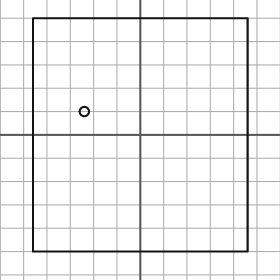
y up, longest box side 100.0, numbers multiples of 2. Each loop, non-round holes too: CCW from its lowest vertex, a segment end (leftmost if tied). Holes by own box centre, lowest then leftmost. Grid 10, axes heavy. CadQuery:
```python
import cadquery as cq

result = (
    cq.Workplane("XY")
    .moveTo(-46.0, -50.0)
    .lineTo(46.0, -50.0)
    .lineTo(46.0, 50.0)
    .lineTo(-46.0, 50.0)
    .close()
    .moveTo(-24.0, 10.0)
    .circle(2.0)
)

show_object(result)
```